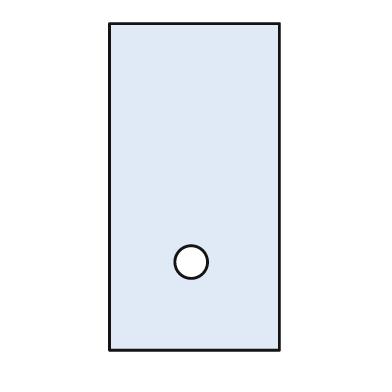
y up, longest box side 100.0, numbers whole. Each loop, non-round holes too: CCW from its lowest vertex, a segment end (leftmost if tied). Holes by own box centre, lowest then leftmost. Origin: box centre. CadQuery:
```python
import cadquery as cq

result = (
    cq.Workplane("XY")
    .moveTo(-26.0, -50.0)
    .lineTo(26.0, -50.0)
    .lineTo(26.0, 50.0)
    .lineTo(-26.0, 50.0)
    .close()
    .moveTo(-1.0, -23.0)
    .circle(5.0)
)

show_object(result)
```